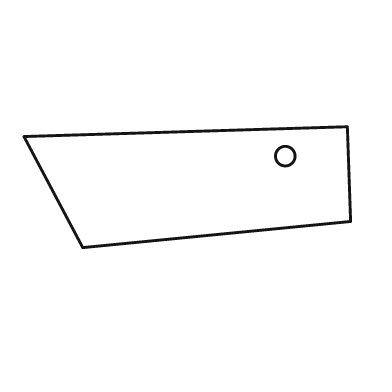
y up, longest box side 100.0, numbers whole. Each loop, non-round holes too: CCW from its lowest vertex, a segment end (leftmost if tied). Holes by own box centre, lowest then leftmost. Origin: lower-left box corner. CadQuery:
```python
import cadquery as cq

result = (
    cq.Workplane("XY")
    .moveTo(18.0, 0.0)
    .lineTo(100.0, 8.0)
    .lineTo(99.0, 37.0)
    .lineTo(0.0, 34.0)
    .close()
    .moveTo(80.0, 28.0)
    .circle(3.0)
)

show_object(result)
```